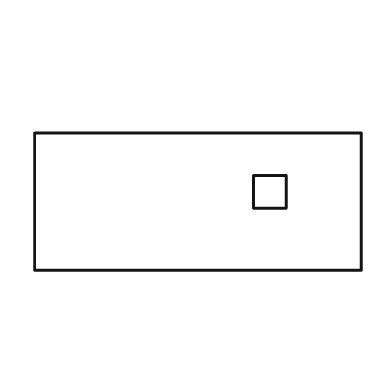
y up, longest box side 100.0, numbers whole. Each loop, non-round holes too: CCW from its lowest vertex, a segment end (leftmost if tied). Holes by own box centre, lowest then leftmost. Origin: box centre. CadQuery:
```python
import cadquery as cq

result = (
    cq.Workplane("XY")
    .moveTo(-50.0, -21.0)
    .lineTo(50.0, -21.0)
    .lineTo(50.0, 21.0)
    .lineTo(-50.0, 21.0)
    .close()
    .moveTo(17.0, -2.0)
    .lineTo(27.0, -2.0)
    .lineTo(27.0, 8.0)
    .lineTo(17.0, 8.0)
    .close()
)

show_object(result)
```